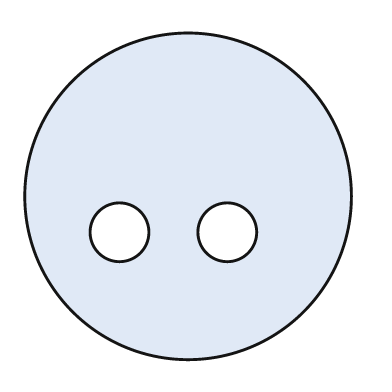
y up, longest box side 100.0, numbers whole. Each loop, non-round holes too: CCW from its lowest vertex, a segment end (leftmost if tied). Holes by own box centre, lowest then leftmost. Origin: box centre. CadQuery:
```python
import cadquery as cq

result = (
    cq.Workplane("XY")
    .moveTo(0.0, 0.0)
    .circle(50.0)
    .moveTo(-21.0, -11.0)
    .circle(9.0)
    .moveTo(12.0, -11.0)
    .circle(9.0)
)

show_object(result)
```